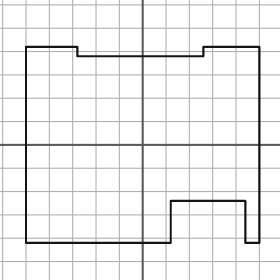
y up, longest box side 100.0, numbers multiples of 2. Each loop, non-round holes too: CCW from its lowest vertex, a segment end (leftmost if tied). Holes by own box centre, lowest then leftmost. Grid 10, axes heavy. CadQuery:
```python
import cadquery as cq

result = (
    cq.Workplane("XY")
    .moveTo(-50.0, -42.0)
    .lineTo(12.0, -42.0)
    .lineTo(12.0, -24.0)
    .lineTo(44.0, -24.0)
    .lineTo(44.0, -42.0)
    .lineTo(50.0, -42.0)
    .lineTo(50.0, 42.0)
    .lineTo(26.0, 42.0)
    .lineTo(26.0, 38.0)
    .lineTo(-28.0, 38.0)
    .lineTo(-28.0, 42.0)
    .lineTo(-50.0, 42.0)
    .close()
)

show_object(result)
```